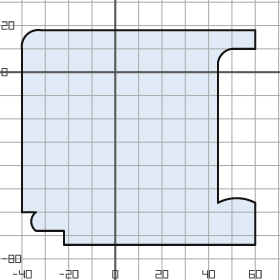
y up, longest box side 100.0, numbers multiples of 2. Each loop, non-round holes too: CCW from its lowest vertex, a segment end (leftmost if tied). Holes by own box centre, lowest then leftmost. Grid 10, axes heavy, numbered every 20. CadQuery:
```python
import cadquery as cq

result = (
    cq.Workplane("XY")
    .moveTo(-22.0, -74.0)
    .lineTo(60.0, -74.0)
    .lineTo(60.0, -56.0)
    .threePointArc((52.0, -54.0), (44.0, -56.0))
    .lineTo(44.0, 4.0)
    .threePointArc((46.0, 8.0), (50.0, 10.0))
    .lineTo(60.0, 10.0)
    .lineTo(60.0, 18.0)
    .lineTo(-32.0, 18.0)
    .threePointArc((-38.0, 16.0), (-40.0, 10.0))
    .lineTo(-40.0, -60.0)
    .lineTo(-34.0, -60.0)
    .threePointArc((-36.0, -64.0), (-34.0, -68.0))
    .lineTo(-22.0, -68.0)
    .close()
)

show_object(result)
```